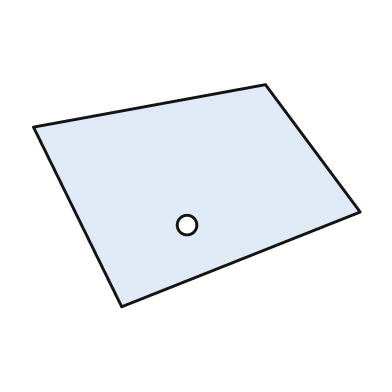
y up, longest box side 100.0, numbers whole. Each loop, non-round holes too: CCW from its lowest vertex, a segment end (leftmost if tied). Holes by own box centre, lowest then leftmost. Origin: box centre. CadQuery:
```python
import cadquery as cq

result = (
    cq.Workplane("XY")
    .moveTo(-23.0, -34.0)
    .lineTo(50.0, -5.0)
    .lineTo(21.0, 34.0)
    .lineTo(-50.0, 21.0)
    .close()
    .moveTo(-3.0, -9.0)
    .circle(3.0)
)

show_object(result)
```